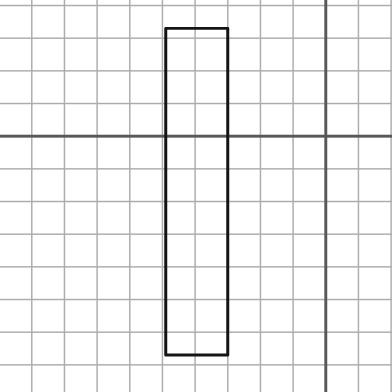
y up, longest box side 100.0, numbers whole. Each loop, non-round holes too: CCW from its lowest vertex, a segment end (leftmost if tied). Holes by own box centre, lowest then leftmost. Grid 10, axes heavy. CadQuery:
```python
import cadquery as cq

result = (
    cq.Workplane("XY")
    .moveTo(-49.0, -67.0)
    .lineTo(-30.0, -67.0)
    .lineTo(-30.0, 33.0)
    .lineTo(-49.0, 33.0)
    .close()
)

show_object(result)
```